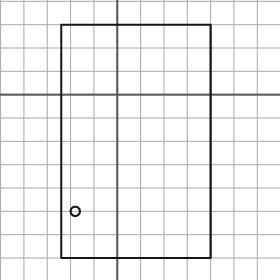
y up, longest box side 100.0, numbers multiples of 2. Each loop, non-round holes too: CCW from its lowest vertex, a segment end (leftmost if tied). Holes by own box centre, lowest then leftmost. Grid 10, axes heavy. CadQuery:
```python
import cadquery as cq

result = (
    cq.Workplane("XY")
    .moveTo(-24.0, -70.0)
    .lineTo(40.0, -70.0)
    .lineTo(40.0, 30.0)
    .lineTo(-24.0, 30.0)
    .close()
    .moveTo(-18.0, -50.0)
    .circle(2.0)
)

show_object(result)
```